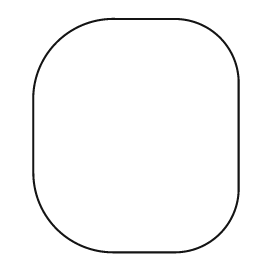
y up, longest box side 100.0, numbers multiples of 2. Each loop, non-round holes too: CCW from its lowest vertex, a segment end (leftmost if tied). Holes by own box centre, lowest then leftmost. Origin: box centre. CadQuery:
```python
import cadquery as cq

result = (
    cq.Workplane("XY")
    .moveTo(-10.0, -50.0)
    .lineTo(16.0, -50.0)
    .threePointArc((36.0, -42.0), (44.0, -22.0))
    .lineTo(44.0, 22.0)
    .threePointArc((36.0, 42.0), (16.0, 50.0))
    .lineTo(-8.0, 50.0)
    .threePointArc((-34.0, 40.0), (-44.0, 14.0))
    .lineTo(-44.0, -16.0)
    .threePointArc((-34.0, -40.0), (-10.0, -50.0))
    .close()
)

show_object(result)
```